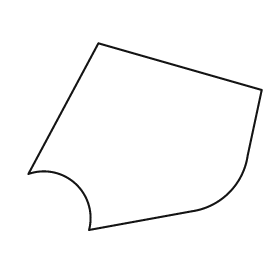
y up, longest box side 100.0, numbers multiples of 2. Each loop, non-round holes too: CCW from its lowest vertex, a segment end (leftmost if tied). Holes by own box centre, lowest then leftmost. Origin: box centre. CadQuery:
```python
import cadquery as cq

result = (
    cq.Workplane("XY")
    .moveTo(-24.0, -40.0)
    .lineTo(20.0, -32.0)
    .threePointArc((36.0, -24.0), (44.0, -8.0))
    .lineTo(50.0, 20.0)
    .lineTo(-20.0, 40.0)
    .lineTo(-50.0, -16.0)
    .threePointArc((-30.0, -20.0), (-24.0, -40.0))
    .close()
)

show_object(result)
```